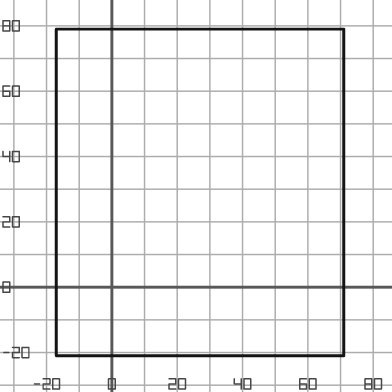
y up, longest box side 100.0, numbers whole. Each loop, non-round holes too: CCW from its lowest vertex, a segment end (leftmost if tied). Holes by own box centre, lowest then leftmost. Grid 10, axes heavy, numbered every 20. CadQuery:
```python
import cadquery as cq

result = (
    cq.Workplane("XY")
    .moveTo(-17.0, -21.0)
    .lineTo(71.0, -21.0)
    .lineTo(71.0, 79.0)
    .lineTo(-17.0, 79.0)
    .close()
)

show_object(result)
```